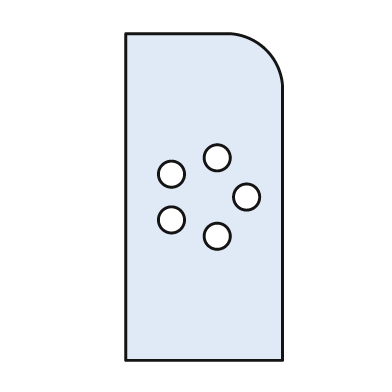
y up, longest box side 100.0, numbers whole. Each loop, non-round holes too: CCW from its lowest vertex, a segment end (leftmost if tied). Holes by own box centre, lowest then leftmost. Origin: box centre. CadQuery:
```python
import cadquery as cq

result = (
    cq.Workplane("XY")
    .moveTo(-24.0, -50.0)
    .lineTo(24.0, -50.0)
    .lineTo(24.0, 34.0)
    .threePointArc((19.0, 45.0), (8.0, 50.0))
    .lineTo(-24.0, 50.0)
    .close()
    .moveTo(4.0, -12.0)
    .circle(4.0)
    .moveTo(-10.0, -7.0)
    .circle(4.0)
    .moveTo(13.0, 0.0)
    .circle(4.0)
    .moveTo(-10.0, 7.0)
    .circle(4.0)
    .moveTo(4.0, 12.0)
    .circle(4.0)
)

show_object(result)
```